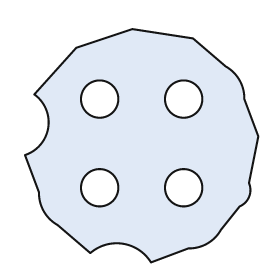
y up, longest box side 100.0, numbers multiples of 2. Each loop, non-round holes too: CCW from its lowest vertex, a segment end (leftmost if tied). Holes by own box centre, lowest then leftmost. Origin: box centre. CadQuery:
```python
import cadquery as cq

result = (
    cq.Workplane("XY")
    .moveTo(4.0, -50.0)
    .lineTo(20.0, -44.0)
    .threePointArc((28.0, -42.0), (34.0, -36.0))
    .lineTo(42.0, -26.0)
    .threePointArc((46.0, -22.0), (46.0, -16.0))
    .lineTo(50.0, 4.0)
    .lineTo(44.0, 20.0)
    .threePointArc((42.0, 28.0), (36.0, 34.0))
    .lineTo(22.0, 46.0)
    .lineTo(-4.0, 50.0)
    .lineTo(-28.0, 42.0)
    .lineTo(-46.0, 22.0)
    .threePointArc((-40.0, 8.0), (-50.0, -4.0))
    .lineTo(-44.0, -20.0)
    .threePointArc((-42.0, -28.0), (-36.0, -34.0))
    .lineTo(-22.0, -46.0)
    .threePointArc((-8.0, -42.0), (4.0, -50.0))
    .close()
    .moveTo(-18.0, -18.0)
    .circle(8.0)
    .moveTo(18.0, -18.0)
    .circle(8.0)
    .moveTo(-18.0, 20.0)
    .circle(8.0)
    .moveTo(18.0, 20.0)
    .circle(8.0)
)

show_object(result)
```